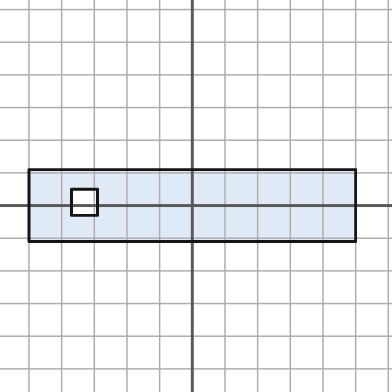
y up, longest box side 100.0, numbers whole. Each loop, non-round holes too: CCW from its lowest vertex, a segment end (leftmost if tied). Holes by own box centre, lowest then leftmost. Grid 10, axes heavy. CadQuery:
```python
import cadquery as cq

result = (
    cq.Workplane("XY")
    .moveTo(-50.0, -11.0)
    .lineTo(50.0, -11.0)
    .lineTo(50.0, 11.0)
    .lineTo(-50.0, 11.0)
    .close()
    .moveTo(-37.0, -3.0)
    .lineTo(-29.0, -3.0)
    .lineTo(-29.0, 5.0)
    .lineTo(-37.0, 5.0)
    .close()
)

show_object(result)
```